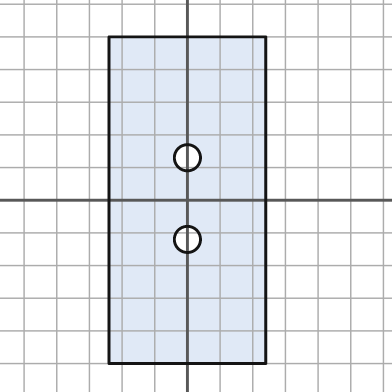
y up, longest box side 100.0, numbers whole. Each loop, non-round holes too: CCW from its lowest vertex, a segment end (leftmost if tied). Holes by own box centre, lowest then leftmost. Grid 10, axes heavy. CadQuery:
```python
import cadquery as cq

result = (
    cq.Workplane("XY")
    .moveTo(-24.0, -50.0)
    .lineTo(24.0, -50.0)
    .lineTo(24.0, 50.0)
    .lineTo(-24.0, 50.0)
    .close()
    .moveTo(0.0, -12.0)
    .circle(4.0)
    .moveTo(0.0, 13.0)
    .circle(4.0)
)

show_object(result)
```